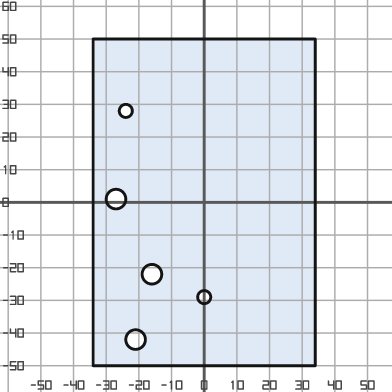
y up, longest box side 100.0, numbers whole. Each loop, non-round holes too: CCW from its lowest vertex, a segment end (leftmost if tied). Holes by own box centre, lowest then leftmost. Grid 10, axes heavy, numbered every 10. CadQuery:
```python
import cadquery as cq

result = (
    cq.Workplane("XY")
    .moveTo(-34.0, -50.0)
    .lineTo(34.0, -50.0)
    .lineTo(34.0, 50.0)
    .lineTo(-34.0, 50.0)
    .close()
    .moveTo(-21.0, -42.0)
    .circle(3.0)
    .moveTo(0.0, -29.0)
    .circle(2.0)
    .moveTo(-16.0, -22.0)
    .circle(3.0)
    .moveTo(-27.0, 1.0)
    .circle(3.0)
    .moveTo(-24.0, 28.0)
    .circle(2.0)
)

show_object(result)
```